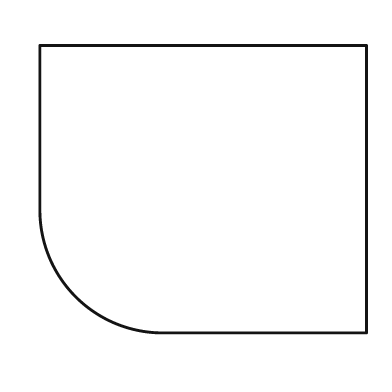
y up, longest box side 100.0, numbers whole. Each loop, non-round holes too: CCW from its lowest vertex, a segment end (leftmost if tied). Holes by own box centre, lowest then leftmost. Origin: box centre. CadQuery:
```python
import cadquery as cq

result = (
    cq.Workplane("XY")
    .moveTo(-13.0, -44.0)
    .lineTo(50.0, -44.0)
    .lineTo(50.0, 44.0)
    .lineTo(-50.0, 44.0)
    .lineTo(-50.0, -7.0)
    .threePointArc((-39.0, -33.0), (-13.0, -44.0))
    .close()
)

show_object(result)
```